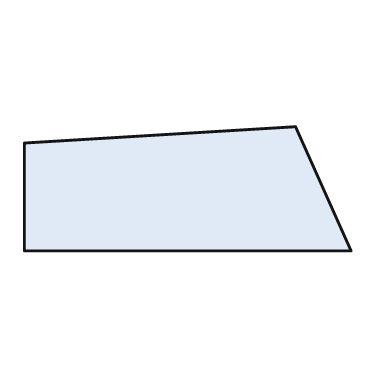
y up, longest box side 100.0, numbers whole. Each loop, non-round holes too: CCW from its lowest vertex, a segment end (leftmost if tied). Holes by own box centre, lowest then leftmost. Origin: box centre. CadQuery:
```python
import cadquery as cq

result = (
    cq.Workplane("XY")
    .moveTo(-50.0, -19.0)
    .lineTo(50.0, -19.0)
    .lineTo(33.0, 19.0)
    .lineTo(-50.0, 14.0)
    .close()
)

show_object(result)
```